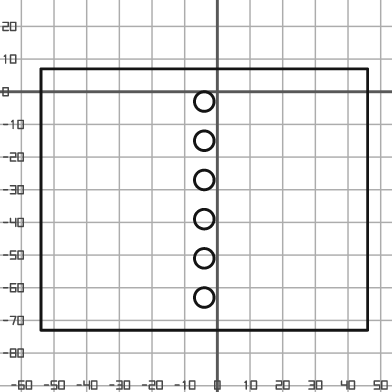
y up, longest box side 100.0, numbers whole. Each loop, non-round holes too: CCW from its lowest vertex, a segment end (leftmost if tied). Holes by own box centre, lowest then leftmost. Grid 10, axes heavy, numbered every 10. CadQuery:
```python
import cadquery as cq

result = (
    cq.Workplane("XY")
    .moveTo(-54.0, -73.0)
    .lineTo(46.0, -73.0)
    .lineTo(46.0, 7.0)
    .lineTo(-54.0, 7.0)
    .close()
    .moveTo(-4.0, -63.0)
    .circle(3.0)
    .moveTo(-4.0, -51.0)
    .circle(3.0)
    .moveTo(-4.0, -39.0)
    .circle(3.0)
    .moveTo(-4.0, -27.0)
    .circle(3.0)
    .moveTo(-4.0, -15.0)
    .circle(3.0)
    .moveTo(-4.0, -3.0)
    .circle(3.0)
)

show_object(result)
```